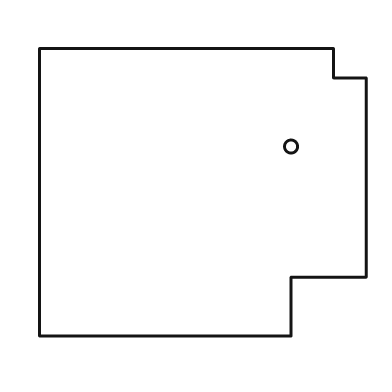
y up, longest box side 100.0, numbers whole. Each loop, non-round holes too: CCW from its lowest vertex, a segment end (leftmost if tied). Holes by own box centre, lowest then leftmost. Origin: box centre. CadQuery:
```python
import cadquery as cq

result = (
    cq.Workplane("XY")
    .moveTo(-50.0, -44.0)
    .lineTo(27.0, -44.0)
    .lineTo(27.0, -26.0)
    .lineTo(50.0, -26.0)
    .lineTo(50.0, 35.0)
    .lineTo(40.0, 35.0)
    .lineTo(40.0, 44.0)
    .lineTo(-50.0, 44.0)
    .close()
    .moveTo(27.0, 14.0)
    .circle(2.0)
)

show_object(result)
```